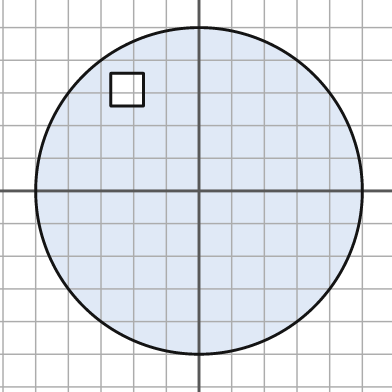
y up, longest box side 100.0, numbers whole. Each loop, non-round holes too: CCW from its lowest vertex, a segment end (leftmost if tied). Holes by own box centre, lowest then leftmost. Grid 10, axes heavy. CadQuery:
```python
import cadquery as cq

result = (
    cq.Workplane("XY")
    .moveTo(0.0, 0.0)
    .circle(50.0)
    .moveTo(-27.0, 26.0)
    .lineTo(-17.0, 26.0)
    .lineTo(-17.0, 36.0)
    .lineTo(-27.0, 36.0)
    .close()
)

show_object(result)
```